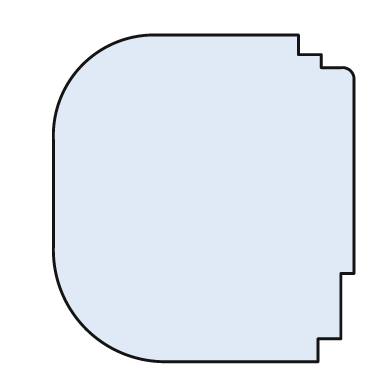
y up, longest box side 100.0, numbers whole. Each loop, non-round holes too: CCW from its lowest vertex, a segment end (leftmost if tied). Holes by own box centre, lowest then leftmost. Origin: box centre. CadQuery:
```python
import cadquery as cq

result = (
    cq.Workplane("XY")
    .moveTo(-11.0, -50.0)
    .lineTo(35.0, -50.0)
    .lineTo(35.0, -43.0)
    .lineTo(42.0, -43.0)
    .lineTo(42.0, -23.0)
    .lineTo(46.0, -23.0)
    .lineTo(46.0, 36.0)
    .threePointArc((45.0, 39.0), (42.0, 40.0))
    .lineTo(36.0, 40.0)
    .lineTo(36.0, 44.0)
    .lineTo(29.0, 44.0)
    .lineTo(29.0, 50.0)
    .lineTo(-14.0, 50.0)
    .threePointArc((-37.0, 41.0), (-46.0, 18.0))
    .lineTo(-46.0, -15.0)
    .threePointArc((-36.0, -40.0), (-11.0, -50.0))
    .close()
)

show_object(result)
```